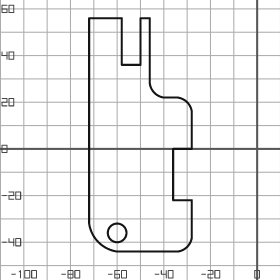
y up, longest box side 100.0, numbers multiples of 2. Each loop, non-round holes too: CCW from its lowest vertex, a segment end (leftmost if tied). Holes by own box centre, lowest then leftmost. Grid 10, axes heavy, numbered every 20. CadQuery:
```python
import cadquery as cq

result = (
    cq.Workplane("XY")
    .moveTo(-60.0, -44.0)
    .lineTo(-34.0, -44.0)
    .threePointArc((-30.0, -42.0), (-28.0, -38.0))
    .lineTo(-28.0, -22.0)
    .lineTo(-36.0, -22.0)
    .lineTo(-36.0, 0.0)
    .lineTo(-28.0, 0.0)
    .lineTo(-28.0, 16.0)
    .threePointArc((-30.0, 20.0), (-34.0, 22.0))
    .lineTo(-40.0, 22.0)
    .threePointArc((-44.0, 24.0), (-46.0, 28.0))
    .lineTo(-46.0, 56.0)
    .lineTo(-50.0, 56.0)
    .lineTo(-50.0, 36.0)
    .lineTo(-58.0, 36.0)
    .lineTo(-58.0, 56.0)
    .lineTo(-72.0, 56.0)
    .lineTo(-72.0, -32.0)
    .threePointArc((-68.0, -40.0), (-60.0, -44.0))
    .close()
    .moveTo(-60.0, -36.0)
    .circle(4.0)
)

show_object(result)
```